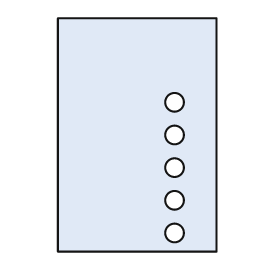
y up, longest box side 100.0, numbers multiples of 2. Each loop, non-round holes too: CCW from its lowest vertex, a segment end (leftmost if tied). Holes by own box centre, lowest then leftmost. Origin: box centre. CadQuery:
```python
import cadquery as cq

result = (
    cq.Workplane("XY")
    .moveTo(-34.0, -50.0)
    .lineTo(34.0, -50.0)
    .lineTo(34.0, 50.0)
    .lineTo(-34.0, 50.0)
    .close()
    .moveTo(16.0, -42.0)
    .circle(4.0)
    .moveTo(16.0, -28.0)
    .circle(4.0)
    .moveTo(16.0, -14.0)
    .circle(4.0)
    .moveTo(16.0, 0.0)
    .circle(4.0)
    .moveTo(16.0, 14.0)
    .circle(4.0)
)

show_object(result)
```